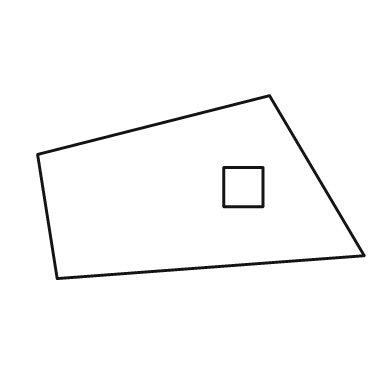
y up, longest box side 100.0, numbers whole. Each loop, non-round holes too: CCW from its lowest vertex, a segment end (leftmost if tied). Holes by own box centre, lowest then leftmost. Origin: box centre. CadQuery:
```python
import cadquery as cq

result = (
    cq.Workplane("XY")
    .moveTo(-44.0, -28.0)
    .lineTo(50.0, -21.0)
    .lineTo(21.0, 28.0)
    .lineTo(-50.0, 10.0)
    .close()
    .moveTo(7.0, -6.0)
    .lineTo(19.0, -6.0)
    .lineTo(19.0, 6.0)
    .lineTo(7.0, 6.0)
    .close()
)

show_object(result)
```